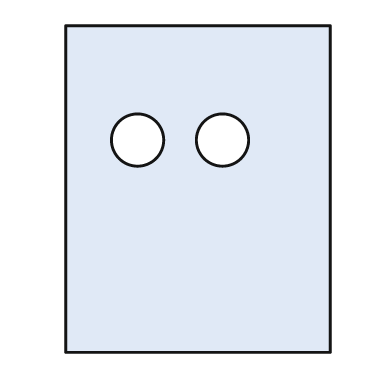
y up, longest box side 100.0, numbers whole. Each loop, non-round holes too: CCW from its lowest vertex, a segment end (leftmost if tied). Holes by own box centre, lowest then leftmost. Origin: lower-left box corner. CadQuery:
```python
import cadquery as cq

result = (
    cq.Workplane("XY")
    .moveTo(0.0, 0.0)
    .lineTo(81.0, 0.0)
    .lineTo(81.0, 100.0)
    .lineTo(0.0, 100.0)
    .close()
    .moveTo(22.0, 65.0)
    .circle(8.0)
    .moveTo(48.0, 65.0)
    .circle(8.0)
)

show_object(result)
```